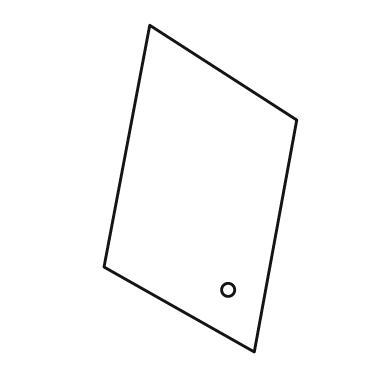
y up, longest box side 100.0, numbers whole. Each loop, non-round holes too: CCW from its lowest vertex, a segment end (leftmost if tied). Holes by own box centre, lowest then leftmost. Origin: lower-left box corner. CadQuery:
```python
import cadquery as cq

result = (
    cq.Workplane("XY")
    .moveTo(46.0, 0.0)
    .lineTo(59.0, 71.0)
    .lineTo(14.0, 100.0)
    .lineTo(0.0, 26.0)
    .close()
    .moveTo(38.0, 19.0)
    .circle(2.0)
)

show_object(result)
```